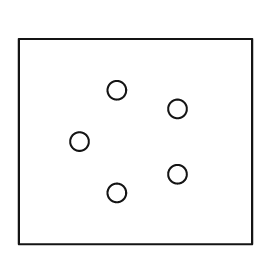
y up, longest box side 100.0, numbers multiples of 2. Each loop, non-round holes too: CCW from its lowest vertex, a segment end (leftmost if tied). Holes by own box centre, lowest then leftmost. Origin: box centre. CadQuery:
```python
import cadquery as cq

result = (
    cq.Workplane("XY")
    .moveTo(-50.0, -44.0)
    .lineTo(50.0, -44.0)
    .lineTo(50.0, 44.0)
    .lineTo(-50.0, 44.0)
    .close()
    .moveTo(-8.0, -22.0)
    .circle(4.0)
    .moveTo(18.0, -14.0)
    .circle(4.0)
    .moveTo(-24.0, 0.0)
    .circle(4.0)
    .moveTo(18.0, 14.0)
    .circle(4.0)
    .moveTo(-8.0, 22.0)
    .circle(4.0)
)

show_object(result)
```